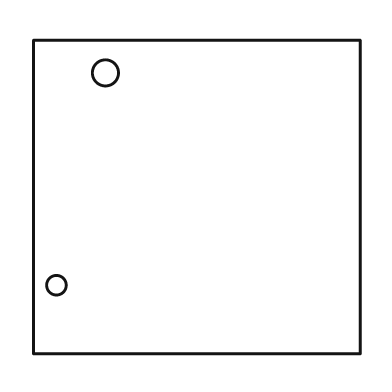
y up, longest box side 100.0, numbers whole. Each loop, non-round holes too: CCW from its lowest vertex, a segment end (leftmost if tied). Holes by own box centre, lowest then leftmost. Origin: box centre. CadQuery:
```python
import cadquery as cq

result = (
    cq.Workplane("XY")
    .moveTo(-50.0, -48.0)
    .lineTo(50.0, -48.0)
    .lineTo(50.0, 48.0)
    .lineTo(-50.0, 48.0)
    .close()
    .moveTo(-43.0, -27.0)
    .circle(3.0)
    .moveTo(-28.0, 38.0)
    .circle(4.0)
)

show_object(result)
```